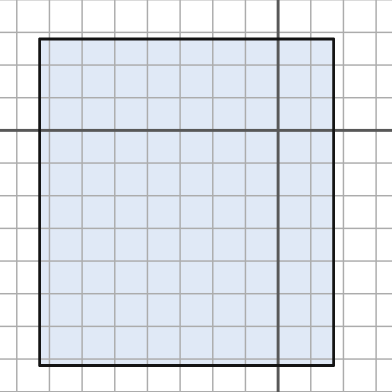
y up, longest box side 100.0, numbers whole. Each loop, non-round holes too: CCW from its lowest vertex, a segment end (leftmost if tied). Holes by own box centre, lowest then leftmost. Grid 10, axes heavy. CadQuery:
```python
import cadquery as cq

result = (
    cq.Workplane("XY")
    .moveTo(-73.0, -72.0)
    .lineTo(17.0, -72.0)
    .lineTo(17.0, 28.0)
    .lineTo(-73.0, 28.0)
    .close()
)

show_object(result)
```